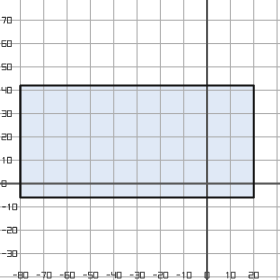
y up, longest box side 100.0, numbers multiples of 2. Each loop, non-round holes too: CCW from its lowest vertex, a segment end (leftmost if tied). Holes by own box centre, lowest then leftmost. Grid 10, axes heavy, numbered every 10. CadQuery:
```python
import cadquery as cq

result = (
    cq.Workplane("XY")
    .moveTo(-80.0, -6.0)
    .lineTo(20.0, -6.0)
    .lineTo(20.0, 42.0)
    .lineTo(-80.0, 42.0)
    .close()
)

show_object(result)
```